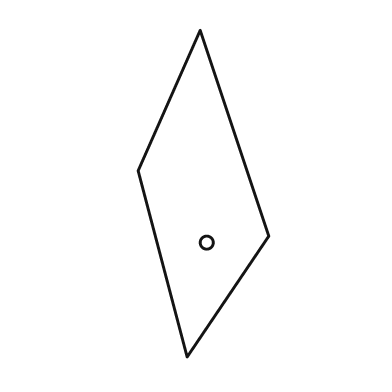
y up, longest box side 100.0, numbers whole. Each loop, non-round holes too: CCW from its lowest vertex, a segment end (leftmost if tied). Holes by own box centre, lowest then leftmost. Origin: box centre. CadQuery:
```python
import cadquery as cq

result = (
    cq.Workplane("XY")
    .moveTo(-5.0, -50.0)
    .lineTo(20.0, -13.0)
    .lineTo(-1.0, 50.0)
    .lineTo(-20.0, 7.0)
    .close()
    .moveTo(1.0, -15.0)
    .circle(2.0)
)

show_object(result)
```